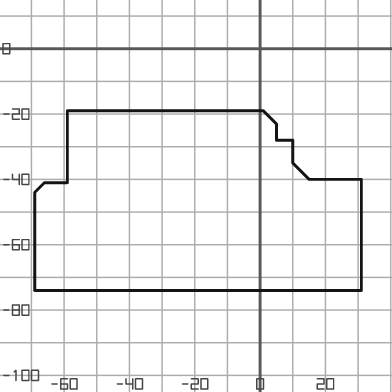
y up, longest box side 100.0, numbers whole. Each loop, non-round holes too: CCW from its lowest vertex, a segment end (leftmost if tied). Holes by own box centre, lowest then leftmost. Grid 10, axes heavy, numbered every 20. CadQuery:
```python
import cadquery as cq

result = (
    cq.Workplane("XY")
    .moveTo(-69.0, -74.0)
    .lineTo(31.0, -74.0)
    .lineTo(31.0, -40.0)
    .lineTo(15.0, -40.0)
    .lineTo(10.0, -35.0)
    .lineTo(10.0, -28.0)
    .lineTo(5.0, -28.0)
    .lineTo(5.0, -23.0)
    .lineTo(1.0, -19.0)
    .lineTo(-59.0, -19.0)
    .lineTo(-59.0, -41.0)
    .lineTo(-66.0, -41.0)
    .lineTo(-69.0, -44.0)
    .close()
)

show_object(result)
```